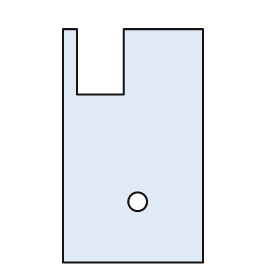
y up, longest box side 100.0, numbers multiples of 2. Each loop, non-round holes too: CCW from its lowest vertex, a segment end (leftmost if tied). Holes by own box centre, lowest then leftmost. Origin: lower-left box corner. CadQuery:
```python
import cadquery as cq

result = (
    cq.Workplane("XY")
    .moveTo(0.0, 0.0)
    .lineTo(60.0, 0.0)
    .lineTo(60.0, 100.0)
    .lineTo(26.0, 100.0)
    .lineTo(26.0, 72.0)
    .lineTo(6.0, 72.0)
    .lineTo(6.0, 100.0)
    .lineTo(0.0, 100.0)
    .close()
    .moveTo(32.0, 26.0)
    .circle(4.0)
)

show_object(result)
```